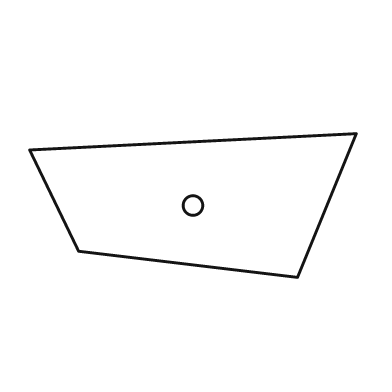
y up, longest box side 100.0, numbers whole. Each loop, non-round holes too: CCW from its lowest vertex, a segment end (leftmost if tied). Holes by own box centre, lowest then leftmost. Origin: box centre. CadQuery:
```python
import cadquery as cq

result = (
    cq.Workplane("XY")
    .moveTo(32.0, -22.0)
    .lineTo(50.0, 22.0)
    .lineTo(-50.0, 17.0)
    .lineTo(-35.0, -14.0)
    .close()
    .moveTo(0.0, 0.0)
    .circle(3.0)
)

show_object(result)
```